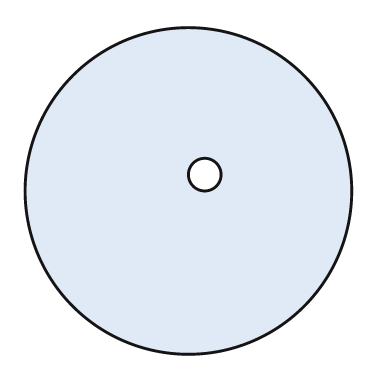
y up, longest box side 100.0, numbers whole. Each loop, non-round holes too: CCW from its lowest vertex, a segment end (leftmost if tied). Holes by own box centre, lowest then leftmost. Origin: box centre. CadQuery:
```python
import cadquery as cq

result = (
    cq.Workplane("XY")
    .moveTo(0.0, 0.0)
    .circle(50.0)
    .moveTo(5.0, 5.0)
    .circle(5.0)
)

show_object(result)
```